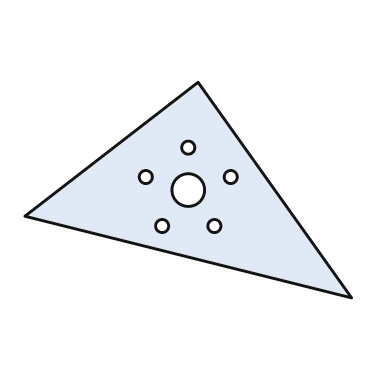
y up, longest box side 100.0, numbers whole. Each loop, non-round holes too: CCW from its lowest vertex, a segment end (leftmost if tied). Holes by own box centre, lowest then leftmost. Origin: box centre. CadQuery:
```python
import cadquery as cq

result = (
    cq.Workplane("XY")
    .moveTo(50.0, -33.0)
    .lineTo(3.0, 33.0)
    .lineTo(-50.0, -8.0)
    .close()
    .moveTo(-8.0, -11.0)
    .circle(2.0)
    .moveTo(8.0, -11.0)
    .circle(2.0)
    .moveTo(0.0, 0.0)
    .circle(5.0)
    .moveTo(-13.0, 4.0)
    .circle(2.0)
    .moveTo(13.0, 4.0)
    .circle(2.0)
    .moveTo(0.0, 13.0)
    .circle(2.0)
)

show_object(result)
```